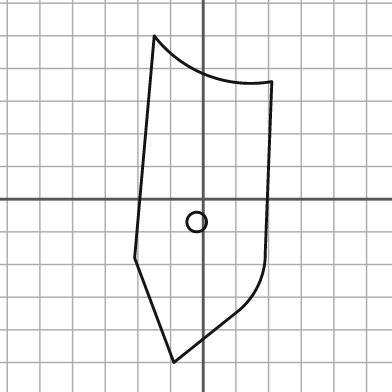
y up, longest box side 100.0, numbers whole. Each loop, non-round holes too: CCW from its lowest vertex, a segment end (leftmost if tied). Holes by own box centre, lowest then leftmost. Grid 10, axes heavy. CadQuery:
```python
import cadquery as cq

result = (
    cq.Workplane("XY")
    .moveTo(-9.0, -50.0)
    .lineTo(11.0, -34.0)
    .threePointArc((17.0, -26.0), (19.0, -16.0))
    .lineTo(21.0, 36.0)
    .threePointArc((1.0, 38.0), (-15.0, 50.0))
    .lineTo(-21.0, -18.0)
    .close()
    .moveTo(-2.0, -7.0)
    .circle(3.0)
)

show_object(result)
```